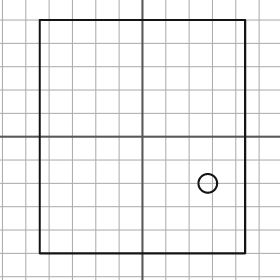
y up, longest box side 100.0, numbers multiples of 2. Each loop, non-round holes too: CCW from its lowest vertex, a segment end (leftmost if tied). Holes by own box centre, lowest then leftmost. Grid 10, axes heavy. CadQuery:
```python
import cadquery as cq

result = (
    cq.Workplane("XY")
    .moveTo(-44.0, -50.0)
    .lineTo(44.0, -50.0)
    .lineTo(44.0, 50.0)
    .lineTo(-44.0, 50.0)
    .close()
    .moveTo(28.0, -20.0)
    .circle(4.0)
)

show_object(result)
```